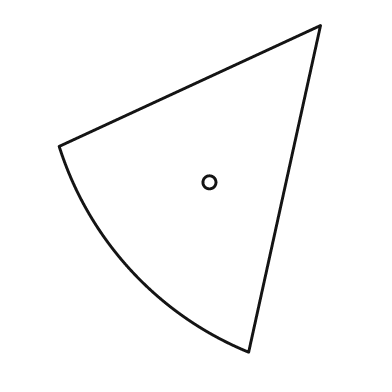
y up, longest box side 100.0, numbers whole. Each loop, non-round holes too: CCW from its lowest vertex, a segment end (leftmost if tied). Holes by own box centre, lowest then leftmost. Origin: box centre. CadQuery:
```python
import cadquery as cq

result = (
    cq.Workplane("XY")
    .moveTo(18.0, -50.0)
    .lineTo(40.0, 50.0)
    .lineTo(-40.0, 13.0)
    .threePointArc((-18.0, -25.0), (18.0, -50.0))
    .close()
    .moveTo(6.0, 2.0)
    .circle(2.0)
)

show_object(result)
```